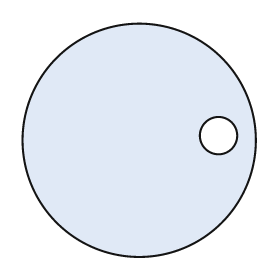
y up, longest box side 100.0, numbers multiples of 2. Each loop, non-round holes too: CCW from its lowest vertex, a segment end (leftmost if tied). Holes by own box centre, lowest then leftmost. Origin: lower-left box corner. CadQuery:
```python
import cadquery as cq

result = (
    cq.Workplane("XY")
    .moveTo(50.0, 50.0)
    .circle(50.0)
    .moveTo(84.0, 52.0)
    .circle(8.0)
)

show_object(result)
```